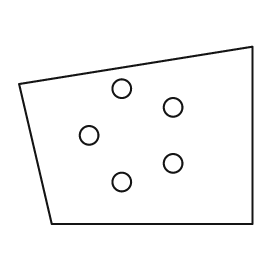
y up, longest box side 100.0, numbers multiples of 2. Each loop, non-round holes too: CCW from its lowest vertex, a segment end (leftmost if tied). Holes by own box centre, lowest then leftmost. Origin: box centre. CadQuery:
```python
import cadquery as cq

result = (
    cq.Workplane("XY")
    .moveTo(-36.0, -38.0)
    .lineTo(50.0, -38.0)
    .lineTo(50.0, 38.0)
    .lineTo(-50.0, 22.0)
    .close()
    .moveTo(-6.0, -20.0)
    .circle(4.0)
    .moveTo(16.0, -12.0)
    .circle(4.0)
    .moveTo(-20.0, 0.0)
    .circle(4.0)
    .moveTo(16.0, 12.0)
    .circle(4.0)
    .moveTo(-6.0, 20.0)
    .circle(4.0)
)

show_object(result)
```